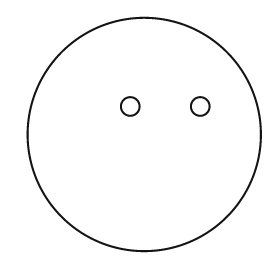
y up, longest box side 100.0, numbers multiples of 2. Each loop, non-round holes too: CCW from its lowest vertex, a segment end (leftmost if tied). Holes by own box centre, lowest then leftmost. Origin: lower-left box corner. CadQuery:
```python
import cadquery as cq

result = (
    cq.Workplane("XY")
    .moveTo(50.0, 50.0)
    .circle(50.0)
    .moveTo(44.0, 62.0)
    .circle(4.0)
    .moveTo(74.0, 62.0)
    .circle(4.0)
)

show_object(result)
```